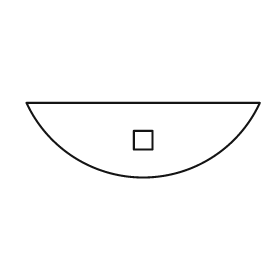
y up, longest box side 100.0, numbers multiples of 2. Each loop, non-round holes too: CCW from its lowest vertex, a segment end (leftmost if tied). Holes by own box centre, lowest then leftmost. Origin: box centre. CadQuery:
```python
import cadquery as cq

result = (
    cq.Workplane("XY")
    .moveTo(-50.0, 16.0)
    .threePointArc((0.0, -16.0), (50.0, 16.0))
    .close()
    .moveTo(-4.0, -4.0)
    .lineTo(4.0, -4.0)
    .lineTo(4.0, 4.0)
    .lineTo(-4.0, 4.0)
    .close()
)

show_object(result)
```